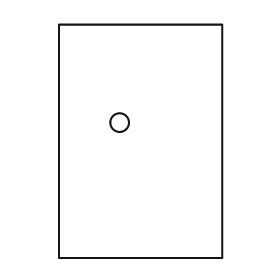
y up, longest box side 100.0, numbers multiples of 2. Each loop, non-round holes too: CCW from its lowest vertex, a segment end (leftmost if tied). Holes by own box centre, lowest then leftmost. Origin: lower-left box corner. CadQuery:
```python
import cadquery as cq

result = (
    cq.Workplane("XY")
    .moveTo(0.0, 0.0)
    .lineTo(70.0, 0.0)
    .lineTo(70.0, 100.0)
    .lineTo(0.0, 100.0)
    .close()
    .moveTo(26.0, 58.0)
    .circle(4.0)
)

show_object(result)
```